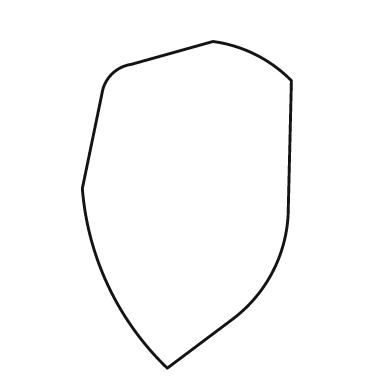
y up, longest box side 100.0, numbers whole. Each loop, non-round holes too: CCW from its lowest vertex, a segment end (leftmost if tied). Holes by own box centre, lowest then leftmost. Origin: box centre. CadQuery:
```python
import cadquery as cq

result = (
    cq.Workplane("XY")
    .moveTo(-6.0, -50.0)
    .lineTo(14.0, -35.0)
    .threePointArc((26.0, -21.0), (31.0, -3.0))
    .lineTo(32.0, 38.0)
    .threePointArc((21.0, 46.0), (8.0, 50.0))
    .lineTo(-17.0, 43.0)
    .threePointArc((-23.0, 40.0), (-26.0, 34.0))
    .lineTo(-32.0, 5.0)
    .threePointArc((-24.0, -25.0), (-6.0, -50.0))
    .close()
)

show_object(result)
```